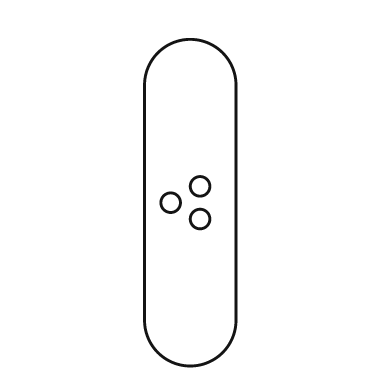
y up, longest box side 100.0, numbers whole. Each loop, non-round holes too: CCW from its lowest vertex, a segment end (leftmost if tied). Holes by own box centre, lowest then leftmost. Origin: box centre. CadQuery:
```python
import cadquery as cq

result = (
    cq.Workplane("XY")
    .moveTo(-14.0, -36.0)
    .threePointArc((0.0, -50.0), (14.0, -36.0))
    .lineTo(14.0, 36.0)
    .threePointArc((0.0, 50.0), (-14.0, 36.0))
    .close()
    .moveTo(3.0, -5.0)
    .circle(3.0)
    .moveTo(-6.0, 0.0)
    .circle(3.0)
    .moveTo(3.0, 5.0)
    .circle(3.0)
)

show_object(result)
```